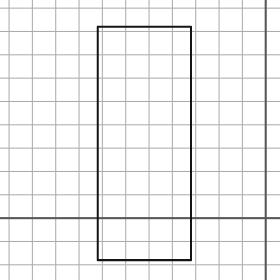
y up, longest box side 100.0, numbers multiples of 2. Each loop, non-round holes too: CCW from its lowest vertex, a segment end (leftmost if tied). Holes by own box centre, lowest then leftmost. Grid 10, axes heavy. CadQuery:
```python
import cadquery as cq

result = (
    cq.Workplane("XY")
    .moveTo(-72.0, -18.0)
    .lineTo(-32.0, -18.0)
    .lineTo(-32.0, 82.0)
    .lineTo(-72.0, 82.0)
    .close()
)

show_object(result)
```